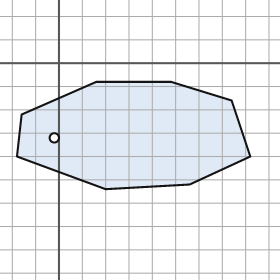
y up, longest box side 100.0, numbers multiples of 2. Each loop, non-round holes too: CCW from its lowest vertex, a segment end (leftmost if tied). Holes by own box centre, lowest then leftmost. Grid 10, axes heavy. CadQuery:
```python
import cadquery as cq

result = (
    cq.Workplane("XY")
    .moveTo(20.0, -54.0)
    .lineTo(56.0, -52.0)
    .lineTo(82.0, -40.0)
    .lineTo(74.0, -16.0)
    .lineTo(48.0, -8.0)
    .lineTo(16.0, -8.0)
    .lineTo(-16.0, -22.0)
    .lineTo(-18.0, -40.0)
    .close()
    .moveTo(-2.0, -32.0)
    .circle(2.0)
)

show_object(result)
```